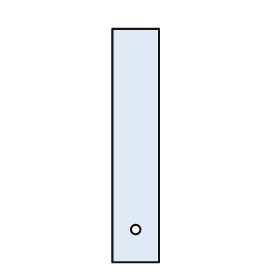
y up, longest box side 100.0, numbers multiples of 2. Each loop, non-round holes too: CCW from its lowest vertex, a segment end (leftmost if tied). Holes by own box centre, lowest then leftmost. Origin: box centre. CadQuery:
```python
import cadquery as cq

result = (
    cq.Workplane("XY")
    .moveTo(-10.0, -50.0)
    .lineTo(10.0, -50.0)
    .lineTo(10.0, 50.0)
    .lineTo(-10.0, 50.0)
    .close()
    .moveTo(0.0, -36.0)
    .circle(2.0)
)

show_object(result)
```